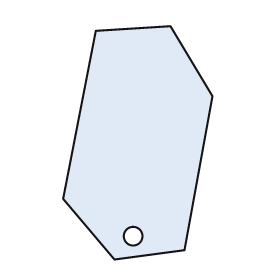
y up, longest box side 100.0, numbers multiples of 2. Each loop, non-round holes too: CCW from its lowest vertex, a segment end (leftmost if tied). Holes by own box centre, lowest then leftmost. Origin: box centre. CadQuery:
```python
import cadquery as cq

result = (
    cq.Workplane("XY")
    .moveTo(-10.0, -50.0)
    .lineTo(20.0, -46.0)
    .lineTo(32.0, 20.0)
    .lineTo(14.0, 50.0)
    .lineTo(-18.0, 48.0)
    .lineTo(-32.0, -24.0)
    .close()
    .moveTo(-2.0, -40.0)
    .circle(4.0)
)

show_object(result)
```